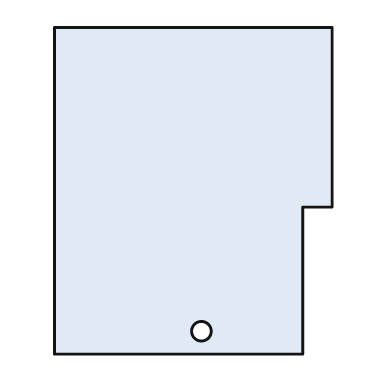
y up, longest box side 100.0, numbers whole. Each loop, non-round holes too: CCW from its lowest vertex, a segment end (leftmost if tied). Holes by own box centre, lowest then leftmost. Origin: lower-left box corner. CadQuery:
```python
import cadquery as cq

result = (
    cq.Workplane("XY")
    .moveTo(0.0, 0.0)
    .lineTo(76.0, 0.0)
    .lineTo(76.0, 45.0)
    .lineTo(85.0, 45.0)
    .lineTo(85.0, 100.0)
    .lineTo(0.0, 100.0)
    .close()
    .moveTo(45.0, 7.0)
    .circle(3.0)
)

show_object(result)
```